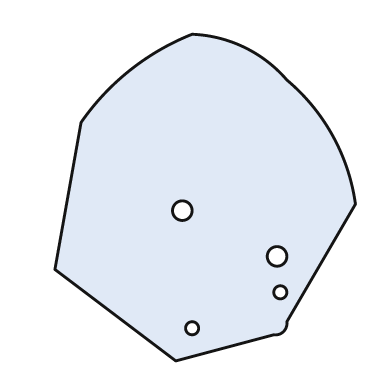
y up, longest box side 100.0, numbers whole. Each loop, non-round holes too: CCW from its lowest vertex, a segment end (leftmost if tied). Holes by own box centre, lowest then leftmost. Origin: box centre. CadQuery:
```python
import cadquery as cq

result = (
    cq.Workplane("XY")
    .moveTo(-9.0, -50.0)
    .lineTo(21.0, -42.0)
    .threePointArc((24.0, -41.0), (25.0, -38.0))
    .lineTo(46.0, -2.0)
    .threePointArc((39.0, 19.0), (25.0, 36.0))
    .threePointArc((12.0, 46.0), (-4.0, 50.0))
    .threePointArc((-23.0, 39.0), (-38.0, 23.0))
    .lineTo(-46.0, -22.0)
    .close()
    .moveTo(-4.0, -40.0)
    .circle(2.0)
    .moveTo(23.0, -29.0)
    .circle(2.0)
    .moveTo(22.0, -18.0)
    .circle(3.0)
    .moveTo(-7.0, -4.0)
    .circle(3.0)
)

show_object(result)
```